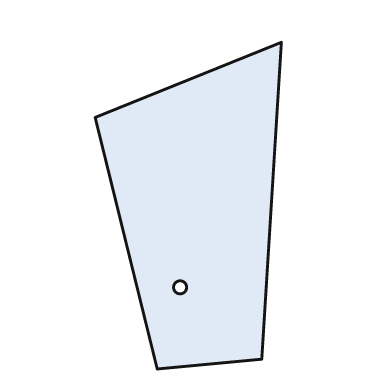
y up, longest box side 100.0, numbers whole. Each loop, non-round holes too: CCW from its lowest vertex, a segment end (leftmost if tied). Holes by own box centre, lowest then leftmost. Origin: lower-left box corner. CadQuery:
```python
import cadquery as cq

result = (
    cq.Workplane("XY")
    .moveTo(19.0, 0.0)
    .lineTo(51.0, 3.0)
    .lineTo(57.0, 100.0)
    .lineTo(0.0, 77.0)
    .close()
    .moveTo(26.0, 25.0)
    .circle(2.0)
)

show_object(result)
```